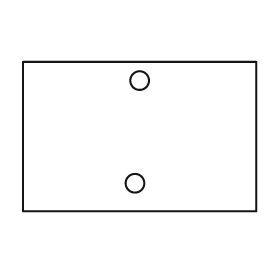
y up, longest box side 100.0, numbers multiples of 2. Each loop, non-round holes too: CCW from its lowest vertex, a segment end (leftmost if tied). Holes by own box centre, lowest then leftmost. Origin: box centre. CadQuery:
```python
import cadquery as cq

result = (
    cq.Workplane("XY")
    .moveTo(-50.0, -32.0)
    .lineTo(50.0, -32.0)
    .lineTo(50.0, 32.0)
    .lineTo(-50.0, 32.0)
    .close()
    .moveTo(-2.0, -20.0)
    .circle(4.0)
    .moveTo(0.0, 24.0)
    .circle(4.0)
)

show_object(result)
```